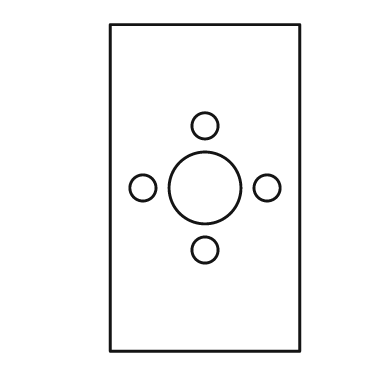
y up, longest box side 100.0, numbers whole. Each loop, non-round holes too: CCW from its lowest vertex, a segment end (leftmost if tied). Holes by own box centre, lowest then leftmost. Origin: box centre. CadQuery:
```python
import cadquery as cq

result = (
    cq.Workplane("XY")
    .moveTo(-29.0, -50.0)
    .lineTo(29.0, -50.0)
    .lineTo(29.0, 50.0)
    .lineTo(-29.0, 50.0)
    .close()
    .moveTo(0.0, -19.0)
    .circle(4.0)
    .moveTo(-19.0, 0.0)
    .circle(4.0)
    .moveTo(0.0, 0.0)
    .circle(11.0)
    .moveTo(19.0, 0.0)
    .circle(4.0)
    .moveTo(0.0, 19.0)
    .circle(4.0)
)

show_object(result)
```